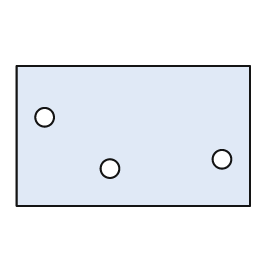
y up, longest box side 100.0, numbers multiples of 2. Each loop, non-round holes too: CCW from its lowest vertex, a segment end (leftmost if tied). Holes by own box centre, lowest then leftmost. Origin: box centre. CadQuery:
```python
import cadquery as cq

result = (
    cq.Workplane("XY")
    .moveTo(-50.0, -30.0)
    .lineTo(50.0, -30.0)
    .lineTo(50.0, 30.0)
    .lineTo(-50.0, 30.0)
    .close()
    .moveTo(-10.0, -14.0)
    .circle(4.0)
    .moveTo(38.0, -10.0)
    .circle(4.0)
    .moveTo(-38.0, 8.0)
    .circle(4.0)
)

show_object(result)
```